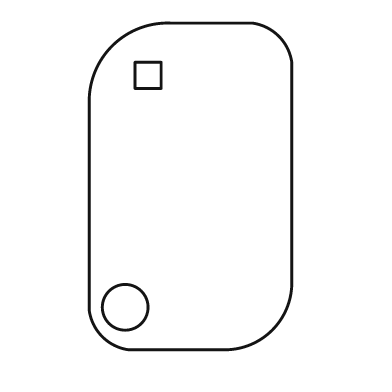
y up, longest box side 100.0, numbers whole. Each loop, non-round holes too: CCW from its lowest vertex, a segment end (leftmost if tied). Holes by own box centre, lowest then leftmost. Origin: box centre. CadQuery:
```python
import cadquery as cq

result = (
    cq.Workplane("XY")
    .moveTo(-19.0, -50.0)
    .lineTo(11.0, -50.0)
    .threePointArc((25.0, -44.0), (31.0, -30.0))
    .lineTo(31.0, 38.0)
    .threePointArc((27.0, 46.0), (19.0, 50.0))
    .lineTo(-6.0, 50.0)
    .threePointArc((-24.0, 43.0), (-31.0, 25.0))
    .lineTo(-31.0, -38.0)
    .threePointArc((-27.0, -46.0), (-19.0, -50.0))
    .close()
    .moveTo(-20.0, -37.0)
    .circle(7.0)
    .moveTo(-17.0, 30.0)
    .lineTo(-9.0, 30.0)
    .lineTo(-9.0, 38.0)
    .lineTo(-17.0, 38.0)
    .close()
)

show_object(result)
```